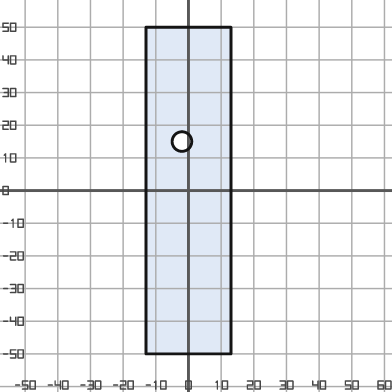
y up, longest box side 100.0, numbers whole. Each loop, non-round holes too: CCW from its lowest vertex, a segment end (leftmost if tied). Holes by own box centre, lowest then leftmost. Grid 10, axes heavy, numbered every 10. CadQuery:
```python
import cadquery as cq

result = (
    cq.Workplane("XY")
    .moveTo(-13.0, -50.0)
    .lineTo(13.0, -50.0)
    .lineTo(13.0, 50.0)
    .lineTo(-13.0, 50.0)
    .close()
    .moveTo(-2.0, 15.0)
    .circle(3.0)
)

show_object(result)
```